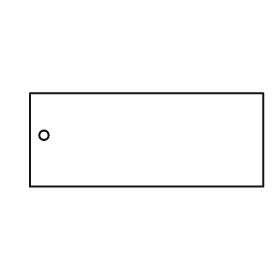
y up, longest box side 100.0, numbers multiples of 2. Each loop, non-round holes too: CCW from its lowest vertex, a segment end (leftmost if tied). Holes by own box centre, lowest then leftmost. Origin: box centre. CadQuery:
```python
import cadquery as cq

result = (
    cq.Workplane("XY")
    .moveTo(-50.0, -20.0)
    .lineTo(50.0, -20.0)
    .lineTo(50.0, 20.0)
    .lineTo(-50.0, 20.0)
    .close()
    .moveTo(-44.0, 2.0)
    .circle(2.0)
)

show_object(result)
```